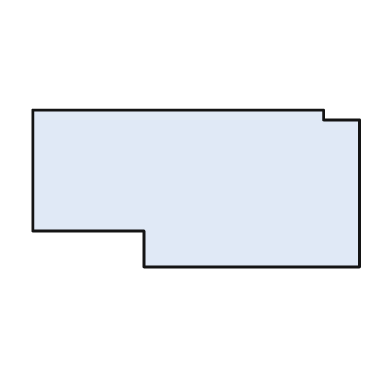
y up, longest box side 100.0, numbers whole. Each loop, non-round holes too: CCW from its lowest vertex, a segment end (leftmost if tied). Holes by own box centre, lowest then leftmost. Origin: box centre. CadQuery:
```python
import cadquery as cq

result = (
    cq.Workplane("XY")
    .moveTo(-16.0, -24.0)
    .lineTo(50.0, -24.0)
    .lineTo(50.0, 21.0)
    .lineTo(39.0, 21.0)
    .lineTo(39.0, 24.0)
    .lineTo(-50.0, 24.0)
    .lineTo(-50.0, -13.0)
    .lineTo(-16.0, -13.0)
    .close()
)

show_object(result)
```